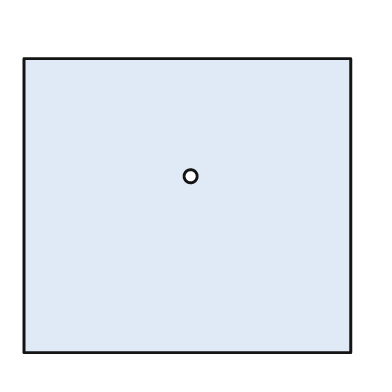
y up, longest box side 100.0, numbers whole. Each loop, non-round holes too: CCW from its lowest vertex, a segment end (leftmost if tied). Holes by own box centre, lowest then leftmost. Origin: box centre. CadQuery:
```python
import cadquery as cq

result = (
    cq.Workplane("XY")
    .moveTo(-50.0, -45.0)
    .lineTo(50.0, -45.0)
    .lineTo(50.0, 45.0)
    .lineTo(-50.0, 45.0)
    .close()
    .moveTo(1.0, 9.0)
    .circle(2.0)
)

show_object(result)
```